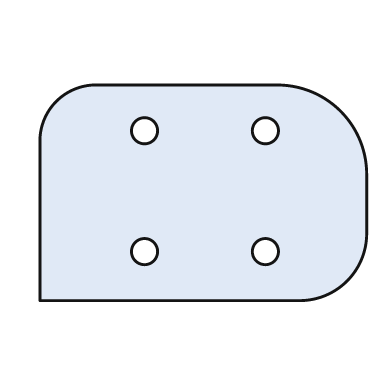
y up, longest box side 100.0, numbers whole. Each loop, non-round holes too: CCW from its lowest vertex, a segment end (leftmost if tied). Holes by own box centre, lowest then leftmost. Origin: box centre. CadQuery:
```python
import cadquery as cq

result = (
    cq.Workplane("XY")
    .moveTo(-50.0, -33.0)
    .lineTo(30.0, -33.0)
    .threePointArc((44.0, -27.0), (50.0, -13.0))
    .lineTo(50.0, 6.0)
    .threePointArc((42.0, 25.0), (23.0, 33.0))
    .lineTo(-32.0, 33.0)
    .threePointArc((-45.0, 28.0), (-50.0, 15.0))
    .close()
    .moveTo(-18.0, -18.0)
    .circle(4.0)
    .moveTo(19.0, -18.0)
    .circle(4.0)
    .moveTo(-18.0, 19.0)
    .circle(4.0)
    .moveTo(19.0, 19.0)
    .circle(4.0)
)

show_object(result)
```